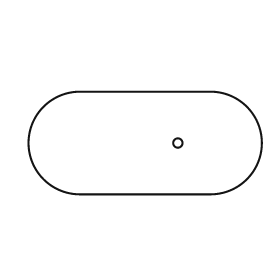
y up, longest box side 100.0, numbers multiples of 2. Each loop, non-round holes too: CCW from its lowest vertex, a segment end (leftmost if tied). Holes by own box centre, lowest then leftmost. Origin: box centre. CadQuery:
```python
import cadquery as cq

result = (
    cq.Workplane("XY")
    .moveTo(-28.0, -22.0)
    .lineTo(28.0, -22.0)
    .threePointArc((50.0, 0.0), (28.0, 22.0))
    .lineTo(-28.0, 22.0)
    .threePointArc((-50.0, 0.0), (-28.0, -22.0))
    .close()
    .moveTo(14.0, 0.0)
    .circle(2.0)
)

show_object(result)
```